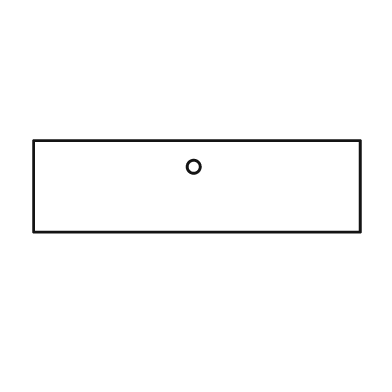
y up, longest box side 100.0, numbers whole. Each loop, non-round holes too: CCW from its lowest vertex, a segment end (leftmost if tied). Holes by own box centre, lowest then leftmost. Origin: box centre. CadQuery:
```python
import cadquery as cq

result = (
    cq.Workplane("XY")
    .moveTo(-50.0, -14.0)
    .lineTo(50.0, -14.0)
    .lineTo(50.0, 14.0)
    .lineTo(-50.0, 14.0)
    .close()
    .moveTo(-1.0, 6.0)
    .circle(2.0)
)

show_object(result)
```